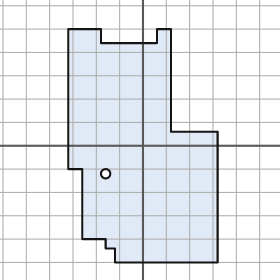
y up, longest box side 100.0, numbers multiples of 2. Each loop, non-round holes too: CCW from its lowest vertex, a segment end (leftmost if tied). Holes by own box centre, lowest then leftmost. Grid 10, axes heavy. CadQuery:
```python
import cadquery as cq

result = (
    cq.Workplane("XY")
    .moveTo(-12.0, -50.0)
    .lineTo(32.0, -50.0)
    .lineTo(32.0, 6.0)
    .lineTo(12.0, 6.0)
    .lineTo(12.0, 50.0)
    .lineTo(6.0, 50.0)
    .lineTo(6.0, 44.0)
    .lineTo(-18.0, 44.0)
    .lineTo(-18.0, 50.0)
    .lineTo(-32.0, 50.0)
    .lineTo(-32.0, -10.0)
    .lineTo(-26.0, -10.0)
    .lineTo(-26.0, -40.0)
    .lineTo(-16.0, -40.0)
    .lineTo(-16.0, -44.0)
    .lineTo(-12.0, -44.0)
    .close()
    .moveTo(-16.0, -12.0)
    .circle(2.0)
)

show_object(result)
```